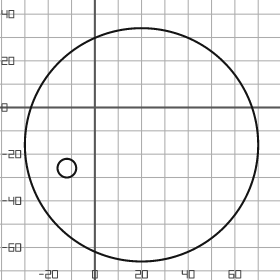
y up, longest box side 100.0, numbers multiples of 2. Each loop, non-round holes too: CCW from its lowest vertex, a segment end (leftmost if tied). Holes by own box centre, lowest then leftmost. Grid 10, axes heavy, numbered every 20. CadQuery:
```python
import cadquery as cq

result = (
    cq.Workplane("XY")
    .moveTo(20.0, -16.0)
    .circle(50.0)
    .moveTo(-12.0, -26.0)
    .circle(4.0)
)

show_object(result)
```